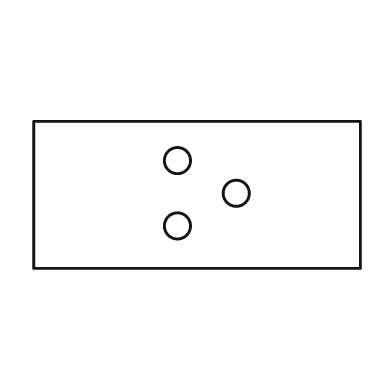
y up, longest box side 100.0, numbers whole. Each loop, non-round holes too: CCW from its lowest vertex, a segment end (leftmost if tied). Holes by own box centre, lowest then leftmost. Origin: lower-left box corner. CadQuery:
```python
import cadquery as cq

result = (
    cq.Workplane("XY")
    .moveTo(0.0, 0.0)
    .lineTo(100.0, 0.0)
    .lineTo(100.0, 45.0)
    .lineTo(0.0, 45.0)
    .close()
    .moveTo(44.0, 13.0)
    .circle(4.0)
    .moveTo(62.0, 23.0)
    .circle(4.0)
    .moveTo(44.0, 33.0)
    .circle(4.0)
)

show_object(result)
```